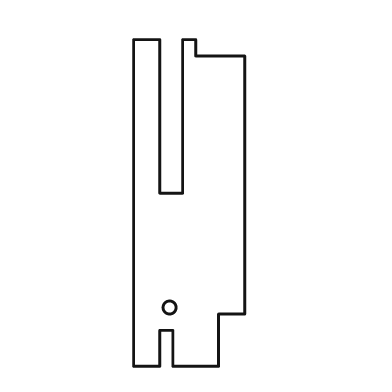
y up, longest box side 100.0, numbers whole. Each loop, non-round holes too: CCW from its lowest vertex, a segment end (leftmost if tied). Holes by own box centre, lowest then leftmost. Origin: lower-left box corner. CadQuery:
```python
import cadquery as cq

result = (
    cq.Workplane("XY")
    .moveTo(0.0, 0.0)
    .lineTo(8.0, 0.0)
    .lineTo(8.0, 11.0)
    .lineTo(12.0, 11.0)
    .lineTo(12.0, 0.0)
    .lineTo(26.0, 0.0)
    .lineTo(26.0, 16.0)
    .lineTo(34.0, 16.0)
    .lineTo(34.0, 95.0)
    .lineTo(19.0, 95.0)
    .lineTo(19.0, 100.0)
    .lineTo(15.0, 100.0)
    .lineTo(15.0, 53.0)
    .lineTo(8.0, 53.0)
    .lineTo(8.0, 100.0)
    .lineTo(0.0, 100.0)
    .close()
    .moveTo(11.0, 18.0)
    .circle(2.0)
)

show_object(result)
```